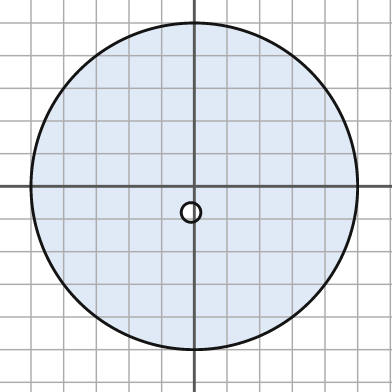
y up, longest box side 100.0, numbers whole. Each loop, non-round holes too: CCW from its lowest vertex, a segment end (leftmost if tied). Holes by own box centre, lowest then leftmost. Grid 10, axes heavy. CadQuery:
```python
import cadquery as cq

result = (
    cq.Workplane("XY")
    .moveTo(0.0, 0.0)
    .circle(50.0)
    .moveTo(-1.0, -8.0)
    .circle(3.0)
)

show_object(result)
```